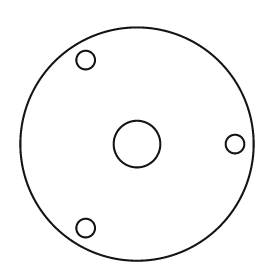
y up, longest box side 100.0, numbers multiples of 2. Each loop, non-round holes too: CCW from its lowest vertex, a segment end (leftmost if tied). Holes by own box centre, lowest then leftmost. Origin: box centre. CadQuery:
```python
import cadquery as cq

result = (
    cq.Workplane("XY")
    .moveTo(0.0, 0.0)
    .circle(50.0)
    .moveTo(-22.0, -36.0)
    .circle(4.0)
    .moveTo(0.0, 0.0)
    .circle(10.0)
    .moveTo(42.0, 0.0)
    .circle(4.0)
    .moveTo(-22.0, 36.0)
    .circle(4.0)
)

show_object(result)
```